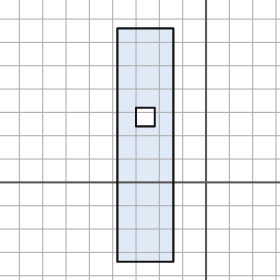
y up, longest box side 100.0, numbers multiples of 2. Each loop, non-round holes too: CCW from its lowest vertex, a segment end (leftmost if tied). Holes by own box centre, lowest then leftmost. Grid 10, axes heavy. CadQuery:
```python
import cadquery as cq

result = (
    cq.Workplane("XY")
    .moveTo(-38.0, -34.0)
    .lineTo(-14.0, -34.0)
    .lineTo(-14.0, 66.0)
    .lineTo(-38.0, 66.0)
    .close()
    .moveTo(-30.0, 24.0)
    .lineTo(-22.0, 24.0)
    .lineTo(-22.0, 32.0)
    .lineTo(-30.0, 32.0)
    .close()
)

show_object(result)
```